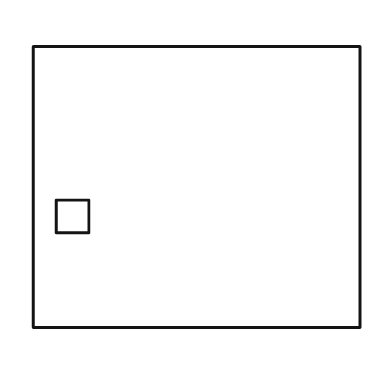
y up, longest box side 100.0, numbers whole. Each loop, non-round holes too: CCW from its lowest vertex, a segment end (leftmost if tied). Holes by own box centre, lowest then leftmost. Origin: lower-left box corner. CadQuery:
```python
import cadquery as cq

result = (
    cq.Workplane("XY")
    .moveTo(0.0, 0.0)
    .lineTo(100.0, 0.0)
    .lineTo(100.0, 86.0)
    .lineTo(0.0, 86.0)
    .close()
    .moveTo(7.0, 29.0)
    .lineTo(17.0, 29.0)
    .lineTo(17.0, 39.0)
    .lineTo(7.0, 39.0)
    .close()
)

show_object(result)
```